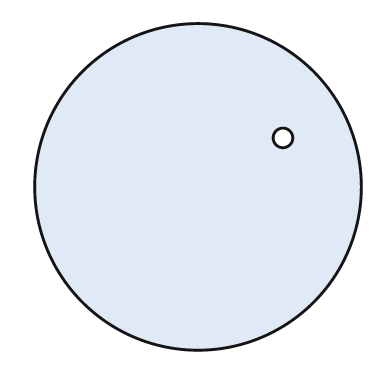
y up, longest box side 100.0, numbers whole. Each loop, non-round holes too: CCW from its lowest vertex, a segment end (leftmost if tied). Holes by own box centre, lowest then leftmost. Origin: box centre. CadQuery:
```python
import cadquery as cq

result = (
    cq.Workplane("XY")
    .moveTo(0.0, 0.0)
    .circle(50.0)
    .moveTo(26.0, 15.0)
    .circle(3.0)
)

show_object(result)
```